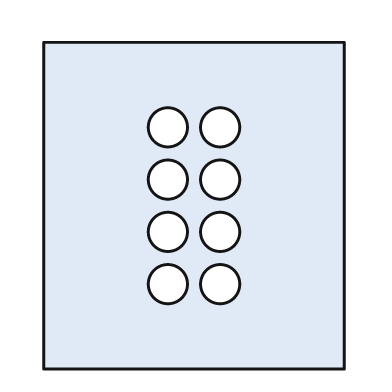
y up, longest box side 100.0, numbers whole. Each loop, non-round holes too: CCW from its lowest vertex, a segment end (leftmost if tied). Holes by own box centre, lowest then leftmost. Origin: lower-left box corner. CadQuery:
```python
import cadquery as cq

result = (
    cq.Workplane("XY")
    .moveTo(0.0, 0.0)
    .lineTo(92.0, 0.0)
    .lineTo(92.0, 100.0)
    .lineTo(0.0, 100.0)
    .close()
    .moveTo(38.0, 26.0)
    .circle(6.0)
    .moveTo(54.0, 26.0)
    .circle(6.0)
    .moveTo(38.0, 42.0)
    .circle(6.0)
    .moveTo(54.0, 42.0)
    .circle(6.0)
    .moveTo(38.0, 58.0)
    .circle(6.0)
    .moveTo(54.0, 58.0)
    .circle(6.0)
    .moveTo(38.0, 74.0)
    .circle(6.0)
    .moveTo(54.0, 74.0)
    .circle(6.0)
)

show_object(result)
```